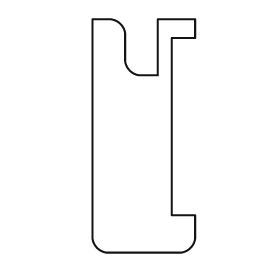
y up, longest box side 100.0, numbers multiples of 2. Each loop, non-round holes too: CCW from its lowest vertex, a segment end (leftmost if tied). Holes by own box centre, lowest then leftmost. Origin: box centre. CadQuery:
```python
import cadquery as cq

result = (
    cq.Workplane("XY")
    .moveTo(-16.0, -50.0)
    .lineTo(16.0, -50.0)
    .threePointArc((20.0, -48.0), (22.0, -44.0))
    .lineTo(22.0, -34.0)
    .lineTo(12.0, -34.0)
    .lineTo(12.0, 42.0)
    .lineTo(22.0, 42.0)
    .lineTo(22.0, 50.0)
    .lineTo(6.0, 50.0)
    .lineTo(6.0, 26.0)
    .lineTo(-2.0, 26.0)
    .threePointArc((-6.0, 28.0), (-8.0, 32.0))
    .lineTo(-8.0, 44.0)
    .threePointArc((-10.0, 48.0), (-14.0, 50.0))
    .lineTo(-22.0, 50.0)
    .lineTo(-22.0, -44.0)
    .threePointArc((-20.0, -48.0), (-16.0, -50.0))
    .close()
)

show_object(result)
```